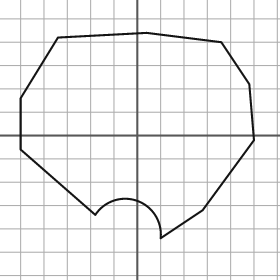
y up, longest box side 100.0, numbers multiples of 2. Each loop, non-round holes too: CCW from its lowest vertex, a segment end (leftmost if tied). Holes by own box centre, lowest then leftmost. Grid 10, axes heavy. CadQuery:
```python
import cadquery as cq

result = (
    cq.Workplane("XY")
    .moveTo(10.0, -44.0)
    .lineTo(28.0, -32.0)
    .lineTo(50.0, -2.0)
    .lineTo(48.0, 22.0)
    .lineTo(36.0, 40.0)
    .lineTo(4.0, 44.0)
    .lineTo(-34.0, 42.0)
    .lineTo(-50.0, 16.0)
    .lineTo(-50.0, -6.0)
    .lineTo(-18.0, -34.0)
    .threePointArc((0.0, -28.0), (10.0, -44.0))
    .close()
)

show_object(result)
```